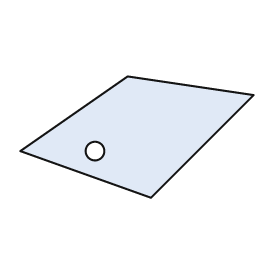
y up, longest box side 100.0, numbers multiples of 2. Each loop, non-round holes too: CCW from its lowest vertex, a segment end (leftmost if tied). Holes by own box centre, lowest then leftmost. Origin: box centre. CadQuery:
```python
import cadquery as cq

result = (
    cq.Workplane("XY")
    .moveTo(6.0, -26.0)
    .lineTo(50.0, 18.0)
    .lineTo(-4.0, 26.0)
    .lineTo(-50.0, -6.0)
    .close()
    .moveTo(-18.0, -6.0)
    .circle(4.0)
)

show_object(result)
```